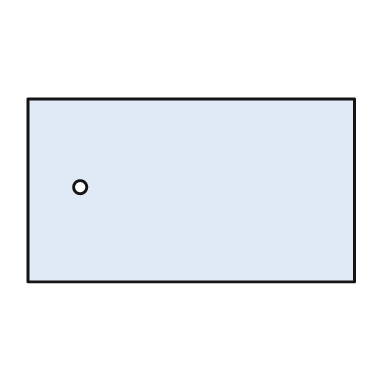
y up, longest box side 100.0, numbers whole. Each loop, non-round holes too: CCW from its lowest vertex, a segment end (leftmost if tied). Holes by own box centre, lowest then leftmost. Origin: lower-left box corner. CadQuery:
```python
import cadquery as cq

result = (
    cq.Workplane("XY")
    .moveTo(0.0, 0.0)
    .lineTo(100.0, 0.0)
    .lineTo(100.0, 56.0)
    .lineTo(0.0, 56.0)
    .close()
    .moveTo(16.0, 29.0)
    .circle(2.0)
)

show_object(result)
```